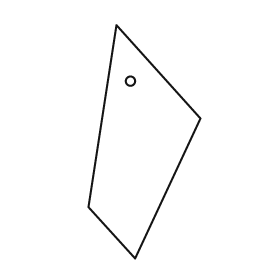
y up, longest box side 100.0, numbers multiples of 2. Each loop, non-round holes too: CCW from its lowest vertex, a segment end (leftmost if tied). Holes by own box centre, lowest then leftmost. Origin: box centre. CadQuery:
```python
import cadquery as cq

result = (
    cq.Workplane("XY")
    .moveTo(-4.0, -50.0)
    .lineTo(24.0, 10.0)
    .lineTo(-12.0, 50.0)
    .lineTo(-24.0, -28.0)
    .close()
    .moveTo(-6.0, 26.0)
    .circle(2.0)
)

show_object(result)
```